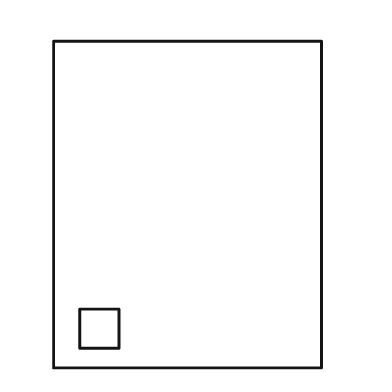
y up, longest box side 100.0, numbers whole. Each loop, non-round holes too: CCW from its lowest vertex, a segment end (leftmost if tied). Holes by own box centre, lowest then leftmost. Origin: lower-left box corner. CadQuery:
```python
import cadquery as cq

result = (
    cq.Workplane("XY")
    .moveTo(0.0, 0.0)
    .lineTo(82.0, 0.0)
    .lineTo(82.0, 100.0)
    .lineTo(0.0, 100.0)
    .close()
    .moveTo(8.0, 6.0)
    .lineTo(20.0, 6.0)
    .lineTo(20.0, 18.0)
    .lineTo(8.0, 18.0)
    .close()
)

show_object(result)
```